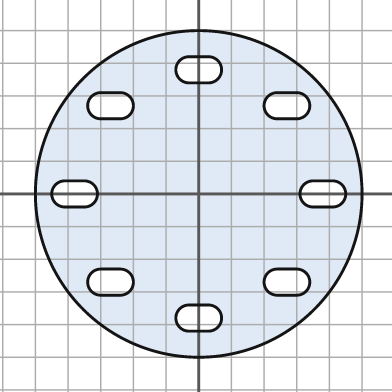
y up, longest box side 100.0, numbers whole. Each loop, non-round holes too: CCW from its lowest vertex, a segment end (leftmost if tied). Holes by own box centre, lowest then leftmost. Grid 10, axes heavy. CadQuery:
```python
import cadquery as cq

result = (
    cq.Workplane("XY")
    .moveTo(0.0, 0.0)
    .circle(50.0)
    .moveTo(-3.0, -42.0)
    .lineTo(3.0, -42.0)
    .threePointArc((7.0, -38.0), (3.0, -34.0))
    .lineTo(-3.0, -34.0)
    .threePointArc((-7.0, -38.0), (-3.0, -42.0))
    .close()
    .moveTo(-30.0, -31.0)
    .lineTo(-24.0, -31.0)
    .threePointArc((-20.0, -27.0), (-24.0, -23.0))
    .lineTo(-30.0, -23.0)
    .threePointArc((-34.0, -27.0), (-30.0, -31.0))
    .close()
    .moveTo(24.0, -31.0)
    .lineTo(30.0, -31.0)
    .threePointArc((34.0, -27.0), (30.0, -23.0))
    .lineTo(24.0, -23.0)
    .threePointArc((20.0, -27.0), (24.0, -31.0))
    .close()
    .moveTo(-41.0, -4.0)
    .lineTo(-35.0, -4.0)
    .threePointArc((-31.0, 0.0), (-35.0, 4.0))
    .lineTo(-41.0, 4.0)
    .threePointArc((-45.0, 0.0), (-41.0, -4.0))
    .close()
    .moveTo(35.0, -4.0)
    .lineTo(41.0, -4.0)
    .threePointArc((45.0, 0.0), (41.0, 4.0))
    .lineTo(35.0, 4.0)
    .threePointArc((31.0, 0.0), (35.0, -4.0))
    .close()
    .moveTo(-30.0, 23.0)
    .lineTo(-24.0, 23.0)
    .threePointArc((-20.0, 27.0), (-24.0, 31.0))
    .lineTo(-30.0, 31.0)
    .threePointArc((-34.0, 27.0), (-30.0, 23.0))
    .close()
    .moveTo(24.0, 23.0)
    .lineTo(30.0, 23.0)
    .threePointArc((34.0, 27.0), (30.0, 31.0))
    .lineTo(24.0, 31.0)
    .threePointArc((20.0, 27.0), (24.0, 23.0))
    .close()
    .moveTo(-3.0, 34.0)
    .lineTo(3.0, 34.0)
    .threePointArc((7.0, 38.0), (3.0, 42.0))
    .lineTo(-3.0, 42.0)
    .threePointArc((-7.0, 38.0), (-3.0, 34.0))
    .close()
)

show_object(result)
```